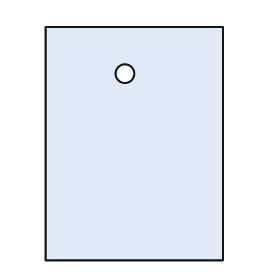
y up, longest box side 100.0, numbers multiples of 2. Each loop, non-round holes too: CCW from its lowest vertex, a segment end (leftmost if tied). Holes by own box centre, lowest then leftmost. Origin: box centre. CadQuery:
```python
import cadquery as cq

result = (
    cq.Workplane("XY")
    .moveTo(-38.0, -50.0)
    .lineTo(38.0, -50.0)
    .lineTo(38.0, 50.0)
    .lineTo(-38.0, 50.0)
    .close()
    .moveTo(-4.0, 30.0)
    .circle(4.0)
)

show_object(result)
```